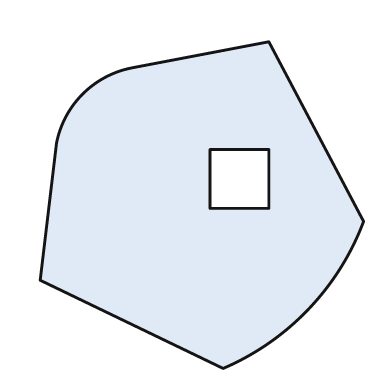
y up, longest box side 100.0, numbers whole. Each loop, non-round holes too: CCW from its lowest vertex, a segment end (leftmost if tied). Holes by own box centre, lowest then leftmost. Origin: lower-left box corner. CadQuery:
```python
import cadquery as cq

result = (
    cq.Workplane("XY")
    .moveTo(56.0, 0.0)
    .threePointArc((82.0, 18.0), (99.0, 45.0))
    .lineTo(70.0, 100.0)
    .lineTo(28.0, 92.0)
    .threePointArc((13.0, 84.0), (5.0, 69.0))
    .lineTo(0.0, 27.0)
    .close()
    .moveTo(52.0, 49.0)
    .lineTo(70.0, 49.0)
    .lineTo(70.0, 67.0)
    .lineTo(52.0, 67.0)
    .close()
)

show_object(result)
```